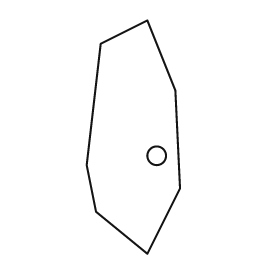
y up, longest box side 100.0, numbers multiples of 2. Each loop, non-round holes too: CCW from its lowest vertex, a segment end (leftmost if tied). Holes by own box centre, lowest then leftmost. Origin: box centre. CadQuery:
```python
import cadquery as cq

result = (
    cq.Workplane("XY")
    .moveTo(6.0, -50.0)
    .lineTo(20.0, -22.0)
    .lineTo(18.0, 20.0)
    .lineTo(6.0, 50.0)
    .lineTo(-14.0, 40.0)
    .lineTo(-20.0, -12.0)
    .lineTo(-16.0, -32.0)
    .close()
    .moveTo(10.0, -8.0)
    .circle(4.0)
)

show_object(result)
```